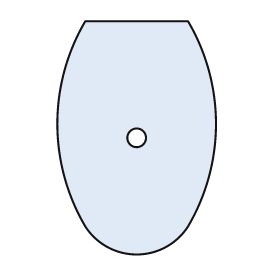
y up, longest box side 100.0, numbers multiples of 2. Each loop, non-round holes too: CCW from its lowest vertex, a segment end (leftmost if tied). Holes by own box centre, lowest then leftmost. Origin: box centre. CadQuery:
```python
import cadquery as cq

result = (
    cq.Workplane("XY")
    .moveTo(-22.0, -38.0)
    .threePointArc((0.0, -50.0), (22.0, -38.0))
    .threePointArc((34.0, 6.0), (22.0, 50.0))
    .lineTo(-22.0, 50.0)
    .threePointArc((-34.0, 6.0), (-22.0, -38.0))
    .close()
    .moveTo(0.0, 0.0)
    .circle(4.0)
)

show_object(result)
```